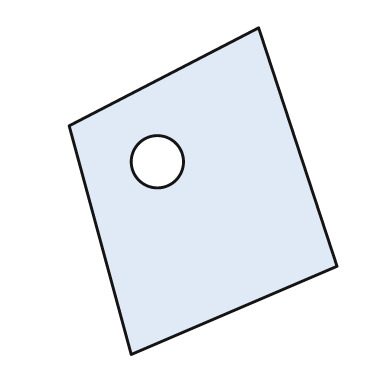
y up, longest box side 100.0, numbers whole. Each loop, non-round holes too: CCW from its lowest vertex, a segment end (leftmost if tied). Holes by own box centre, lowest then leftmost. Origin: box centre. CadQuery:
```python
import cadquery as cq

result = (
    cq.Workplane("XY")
    .moveTo(-22.0, -50.0)
    .lineTo(41.0, -23.0)
    .lineTo(17.0, 50.0)
    .lineTo(-41.0, 20.0)
    .close()
    .moveTo(-14.0, 9.0)
    .circle(8.0)
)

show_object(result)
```